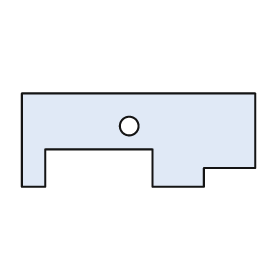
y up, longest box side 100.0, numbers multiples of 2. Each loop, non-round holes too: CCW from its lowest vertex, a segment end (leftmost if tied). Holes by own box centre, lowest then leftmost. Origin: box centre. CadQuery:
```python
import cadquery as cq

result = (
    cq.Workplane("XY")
    .moveTo(-50.0, -20.0)
    .lineTo(-40.0, -20.0)
    .lineTo(-40.0, -4.0)
    .lineTo(6.0, -4.0)
    .lineTo(6.0, -20.0)
    .lineTo(28.0, -20.0)
    .lineTo(28.0, -12.0)
    .lineTo(50.0, -12.0)
    .lineTo(50.0, 20.0)
    .lineTo(-50.0, 20.0)
    .close()
    .moveTo(-4.0, 6.0)
    .circle(4.0)
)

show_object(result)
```